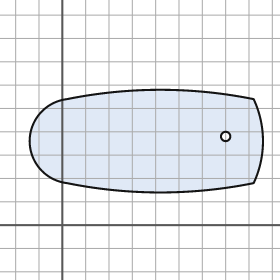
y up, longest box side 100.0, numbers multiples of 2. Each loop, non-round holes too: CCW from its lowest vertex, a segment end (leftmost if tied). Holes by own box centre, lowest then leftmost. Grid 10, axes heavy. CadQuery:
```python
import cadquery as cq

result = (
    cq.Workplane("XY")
    .moveTo(2.0, 18.0)
    .threePointArc((42.0, 14.0), (82.0, 18.0))
    .threePointArc((86.0, 36.0), (82.0, 54.0))
    .threePointArc((42.0, 58.0), (2.0, 54.0))
    .threePointArc((-14.0, 36.0), (2.0, 18.0))
    .close()
    .moveTo(70.0, 38.0)
    .circle(2.0)
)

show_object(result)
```